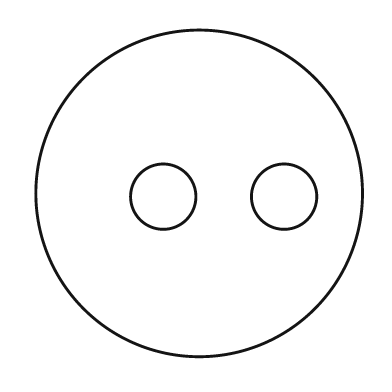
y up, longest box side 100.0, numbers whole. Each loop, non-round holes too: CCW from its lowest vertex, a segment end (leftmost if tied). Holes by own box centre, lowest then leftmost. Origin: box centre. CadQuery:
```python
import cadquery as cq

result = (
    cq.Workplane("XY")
    .moveTo(0.0, 0.0)
    .circle(50.0)
    .moveTo(-11.0, -1.0)
    .circle(10.0)
    .moveTo(26.0, -1.0)
    .circle(10.0)
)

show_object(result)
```